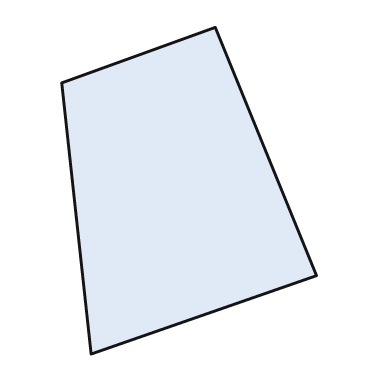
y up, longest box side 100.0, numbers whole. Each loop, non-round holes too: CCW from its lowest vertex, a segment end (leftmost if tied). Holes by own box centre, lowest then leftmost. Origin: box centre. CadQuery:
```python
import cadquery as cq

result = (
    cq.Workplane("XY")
    .moveTo(-30.0, -50.0)
    .lineTo(39.0, -26.0)
    .lineTo(8.0, 50.0)
    .lineTo(-39.0, 33.0)
    .close()
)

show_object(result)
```